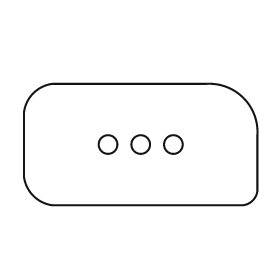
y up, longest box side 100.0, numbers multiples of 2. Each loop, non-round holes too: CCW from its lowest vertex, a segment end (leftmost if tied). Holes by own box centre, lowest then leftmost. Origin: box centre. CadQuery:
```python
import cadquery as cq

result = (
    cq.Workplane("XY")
    .moveTo(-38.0, -26.0)
    .lineTo(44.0, -26.0)
    .threePointArc((48.0, -24.0), (50.0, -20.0))
    .lineTo(50.0, 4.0)
    .threePointArc((44.0, 20.0), (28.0, 26.0))
    .lineTo(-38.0, 26.0)
    .threePointArc((-46.0, 22.0), (-50.0, 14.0))
    .lineTo(-50.0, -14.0)
    .threePointArc((-46.0, -22.0), (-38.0, -26.0))
    .close()
    .moveTo(-14.0, 0.0)
    .circle(4.0)
    .moveTo(0.0, 0.0)
    .circle(4.0)
    .moveTo(14.0, 0.0)
    .circle(4.0)
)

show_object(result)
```